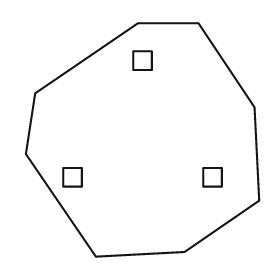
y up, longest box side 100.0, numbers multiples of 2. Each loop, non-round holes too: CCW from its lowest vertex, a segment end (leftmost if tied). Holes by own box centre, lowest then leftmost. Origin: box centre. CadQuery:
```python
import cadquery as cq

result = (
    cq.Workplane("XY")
    .moveTo(-20.0, -50.0)
    .lineTo(18.0, -48.0)
    .lineTo(50.0, -26.0)
    .lineTo(48.0, 14.0)
    .lineTo(24.0, 50.0)
    .lineTo(-2.0, 50.0)
    .lineTo(-46.0, 20.0)
    .lineTo(-50.0, -6.0)
    .close()
    .moveTo(-34.0, -20.0)
    .lineTo(-26.0, -20.0)
    .lineTo(-26.0, -12.0)
    .lineTo(-34.0, -12.0)
    .close()
    .moveTo(26.0, -20.0)
    .lineTo(34.0, -20.0)
    .lineTo(34.0, -12.0)
    .lineTo(26.0, -12.0)
    .close()
    .moveTo(-4.0, 30.0)
    .lineTo(4.0, 30.0)
    .lineTo(4.0, 38.0)
    .lineTo(-4.0, 38.0)
    .close()
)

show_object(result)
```